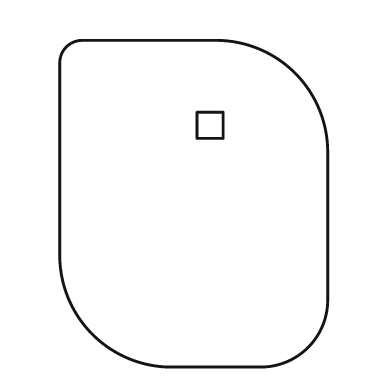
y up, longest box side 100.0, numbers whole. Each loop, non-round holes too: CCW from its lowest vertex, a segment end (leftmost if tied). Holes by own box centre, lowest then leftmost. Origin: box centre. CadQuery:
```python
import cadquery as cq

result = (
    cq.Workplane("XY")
    .moveTo(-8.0, -50.0)
    .lineTo(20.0, -50.0)
    .threePointArc((35.0, -44.0), (41.0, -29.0))
    .lineTo(41.0, 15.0)
    .threePointArc((31.0, 40.0), (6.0, 50.0))
    .lineTo(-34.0, 50.0)
    .threePointArc((-39.0, 48.0), (-41.0, 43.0))
    .lineTo(-41.0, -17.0)
    .threePointArc((-31.0, -40.0), (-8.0, -50.0))
    .close()
    .moveTo(1.0, 20.0)
    .lineTo(9.0, 20.0)
    .lineTo(9.0, 28.0)
    .lineTo(1.0, 28.0)
    .close()
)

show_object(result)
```